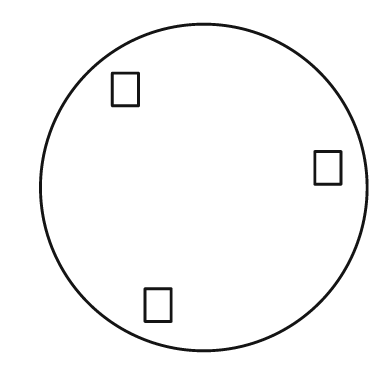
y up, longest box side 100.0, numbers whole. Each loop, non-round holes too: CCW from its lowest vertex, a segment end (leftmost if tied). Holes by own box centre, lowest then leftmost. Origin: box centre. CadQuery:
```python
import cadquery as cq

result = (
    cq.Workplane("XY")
    .moveTo(0.0, 0.0)
    .circle(50.0)
    .moveTo(-18.0, -41.0)
    .lineTo(-10.0, -41.0)
    .lineTo(-10.0, -31.0)
    .lineTo(-18.0, -31.0)
    .close()
    .moveTo(34.0, 1.0)
    .lineTo(42.0, 1.0)
    .lineTo(42.0, 11.0)
    .lineTo(34.0, 11.0)
    .close()
    .moveTo(-28.0, 25.0)
    .lineTo(-20.0, 25.0)
    .lineTo(-20.0, 35.0)
    .lineTo(-28.0, 35.0)
    .close()
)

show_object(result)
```